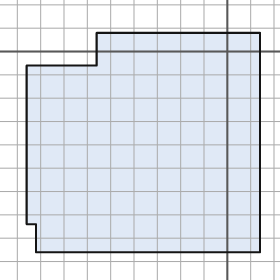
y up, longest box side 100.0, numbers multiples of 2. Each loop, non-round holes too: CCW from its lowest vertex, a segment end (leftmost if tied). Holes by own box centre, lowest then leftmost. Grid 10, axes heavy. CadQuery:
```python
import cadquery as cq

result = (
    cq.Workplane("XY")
    .moveTo(-82.0, -86.0)
    .lineTo(14.0, -86.0)
    .lineTo(14.0, 8.0)
    .lineTo(-56.0, 8.0)
    .lineTo(-56.0, -6.0)
    .lineTo(-86.0, -6.0)
    .lineTo(-86.0, -74.0)
    .lineTo(-82.0, -74.0)
    .close()
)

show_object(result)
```